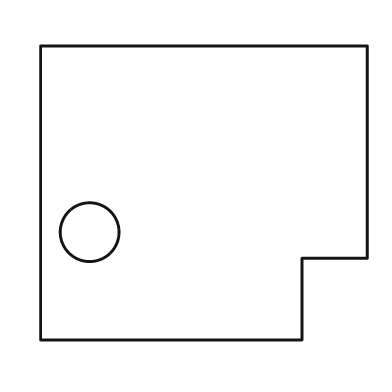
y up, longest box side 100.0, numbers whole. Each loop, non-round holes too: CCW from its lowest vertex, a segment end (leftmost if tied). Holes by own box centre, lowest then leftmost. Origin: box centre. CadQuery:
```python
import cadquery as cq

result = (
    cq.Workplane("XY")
    .moveTo(-50.0, -45.0)
    .lineTo(30.0, -45.0)
    .lineTo(30.0, -20.0)
    .lineTo(50.0, -20.0)
    .lineTo(50.0, 45.0)
    .lineTo(-50.0, 45.0)
    .close()
    .moveTo(-35.0, -12.0)
    .circle(9.0)
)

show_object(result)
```